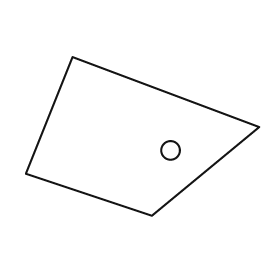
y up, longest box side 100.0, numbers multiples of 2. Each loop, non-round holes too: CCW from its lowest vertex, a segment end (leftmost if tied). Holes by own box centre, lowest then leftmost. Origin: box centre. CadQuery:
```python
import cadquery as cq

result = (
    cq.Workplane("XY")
    .moveTo(4.0, -34.0)
    .lineTo(50.0, 4.0)
    .lineTo(-30.0, 34.0)
    .lineTo(-50.0, -16.0)
    .close()
    .moveTo(12.0, -6.0)
    .circle(4.0)
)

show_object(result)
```